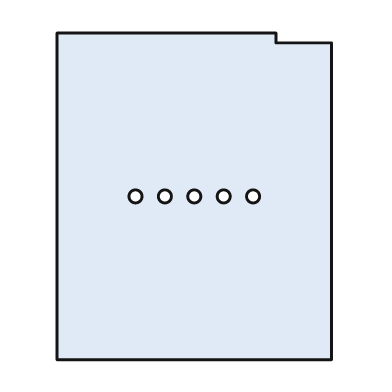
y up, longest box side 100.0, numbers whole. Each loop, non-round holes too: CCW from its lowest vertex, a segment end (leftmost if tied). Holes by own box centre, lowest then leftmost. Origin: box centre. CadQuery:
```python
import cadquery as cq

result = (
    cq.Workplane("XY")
    .moveTo(-42.0, -50.0)
    .lineTo(42.0, -50.0)
    .lineTo(42.0, 47.0)
    .lineTo(25.0, 47.0)
    .lineTo(25.0, 50.0)
    .lineTo(-42.0, 50.0)
    .close()
    .moveTo(-18.0, 0.0)
    .circle(2.0)
    .moveTo(-9.0, 0.0)
    .circle(2.0)
    .moveTo(0.0, 0.0)
    .circle(2.0)
    .moveTo(9.0, 0.0)
    .circle(2.0)
    .moveTo(18.0, 0.0)
    .circle(2.0)
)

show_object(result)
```